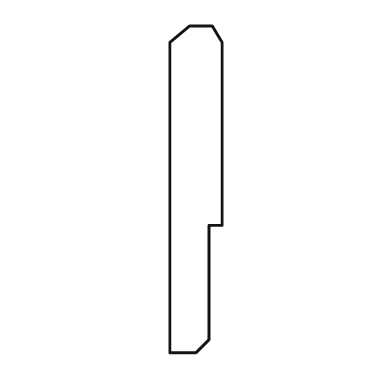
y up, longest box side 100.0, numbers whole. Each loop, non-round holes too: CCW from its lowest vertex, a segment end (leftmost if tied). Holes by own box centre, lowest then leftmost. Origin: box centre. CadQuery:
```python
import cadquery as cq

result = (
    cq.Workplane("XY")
    .moveTo(-8.0, -50.0)
    .lineTo(0.0, -50.0)
    .lineTo(4.0, -46.0)
    .lineTo(4.0, -11.0)
    .lineTo(8.0, -11.0)
    .lineTo(8.0, 45.0)
    .lineTo(5.0, 50.0)
    .lineTo(-2.0, 50.0)
    .lineTo(-8.0, 45.0)
    .close()
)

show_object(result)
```